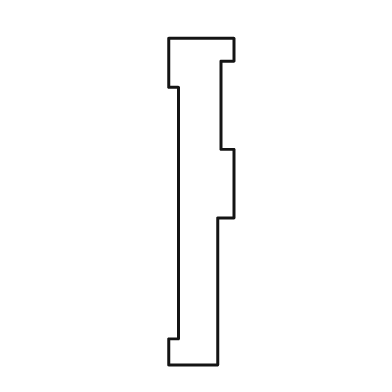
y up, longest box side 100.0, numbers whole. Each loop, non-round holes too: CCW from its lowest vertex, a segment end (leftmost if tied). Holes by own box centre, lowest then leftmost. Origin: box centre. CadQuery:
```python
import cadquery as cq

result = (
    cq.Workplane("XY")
    .moveTo(-10.0, -50.0)
    .lineTo(5.0, -50.0)
    .lineTo(5.0, -5.0)
    .lineTo(10.0, -5.0)
    .lineTo(10.0, 16.0)
    .lineTo(6.0, 16.0)
    .lineTo(6.0, 43.0)
    .lineTo(10.0, 43.0)
    .lineTo(10.0, 50.0)
    .lineTo(-10.0, 50.0)
    .lineTo(-10.0, 35.0)
    .lineTo(-7.0, 35.0)
    .lineTo(-7.0, -42.0)
    .lineTo(-10.0, -42.0)
    .close()
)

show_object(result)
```